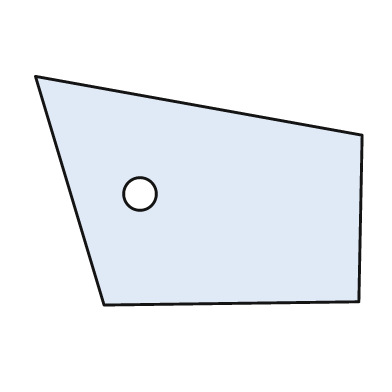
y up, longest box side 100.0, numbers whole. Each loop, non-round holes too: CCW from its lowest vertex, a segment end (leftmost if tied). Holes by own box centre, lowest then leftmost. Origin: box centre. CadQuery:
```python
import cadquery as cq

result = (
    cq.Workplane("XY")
    .moveTo(-29.0, -35.0)
    .lineTo(49.0, -34.0)
    .lineTo(50.0, 17.0)
    .lineTo(-50.0, 35.0)
    .close()
    .moveTo(-18.0, -1.0)
    .circle(5.0)
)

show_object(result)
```